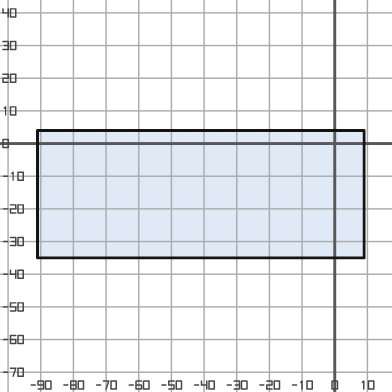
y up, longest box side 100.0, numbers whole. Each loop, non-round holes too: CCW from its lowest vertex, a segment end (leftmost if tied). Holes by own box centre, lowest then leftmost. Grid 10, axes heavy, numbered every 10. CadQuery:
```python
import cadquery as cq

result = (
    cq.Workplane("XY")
    .moveTo(-91.0, -35.0)
    .lineTo(9.0, -35.0)
    .lineTo(9.0, 4.0)
    .lineTo(-91.0, 4.0)
    .close()
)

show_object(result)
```